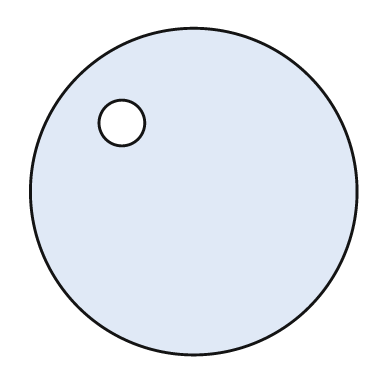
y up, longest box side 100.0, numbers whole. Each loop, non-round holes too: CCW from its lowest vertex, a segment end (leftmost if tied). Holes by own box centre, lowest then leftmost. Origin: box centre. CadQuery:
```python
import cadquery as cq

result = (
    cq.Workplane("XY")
    .moveTo(0.0, 0.0)
    .circle(50.0)
    .moveTo(-22.0, 21.0)
    .circle(7.0)
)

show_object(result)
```